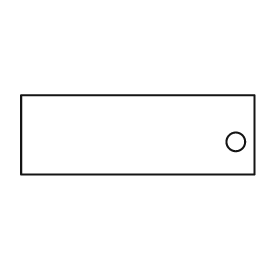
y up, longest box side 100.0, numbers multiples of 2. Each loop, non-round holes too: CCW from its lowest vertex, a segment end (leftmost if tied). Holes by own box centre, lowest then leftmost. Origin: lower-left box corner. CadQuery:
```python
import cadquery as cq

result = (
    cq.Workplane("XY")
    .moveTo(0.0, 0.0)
    .lineTo(100.0, 0.0)
    .lineTo(100.0, 34.0)
    .lineTo(0.0, 34.0)
    .close()
    .moveTo(92.0, 14.0)
    .circle(4.0)
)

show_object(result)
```